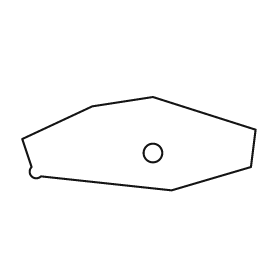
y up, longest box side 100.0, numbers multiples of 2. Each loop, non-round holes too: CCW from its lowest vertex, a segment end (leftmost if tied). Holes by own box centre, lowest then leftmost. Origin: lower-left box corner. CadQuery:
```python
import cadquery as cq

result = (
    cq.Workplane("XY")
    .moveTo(64.0, 0.0)
    .lineTo(98.0, 10.0)
    .lineTo(100.0, 26.0)
    .lineTo(56.0, 40.0)
    .lineTo(30.0, 36.0)
    .lineTo(0.0, 22.0)
    .lineTo(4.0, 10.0)
    .threePointArc((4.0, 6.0), (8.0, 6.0))
    .close()
    .moveTo(56.0, 16.0)
    .circle(4.0)
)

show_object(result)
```